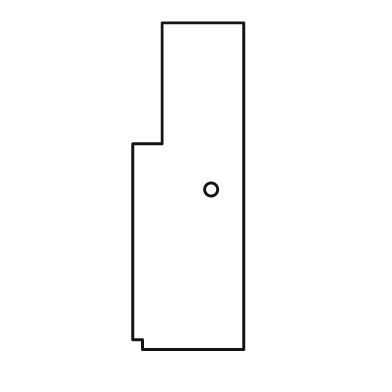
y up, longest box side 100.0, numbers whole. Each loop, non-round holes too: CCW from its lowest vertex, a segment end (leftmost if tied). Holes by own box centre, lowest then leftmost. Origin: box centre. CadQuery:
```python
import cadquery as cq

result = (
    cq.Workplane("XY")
    .moveTo(-14.0, -50.0)
    .lineTo(17.0, -50.0)
    .lineTo(17.0, 50.0)
    .lineTo(-8.0, 50.0)
    .lineTo(-8.0, 13.0)
    .lineTo(-17.0, 13.0)
    .lineTo(-17.0, -47.0)
    .lineTo(-14.0, -47.0)
    .close()
    .moveTo(7.0, -1.0)
    .circle(2.0)
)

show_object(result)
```